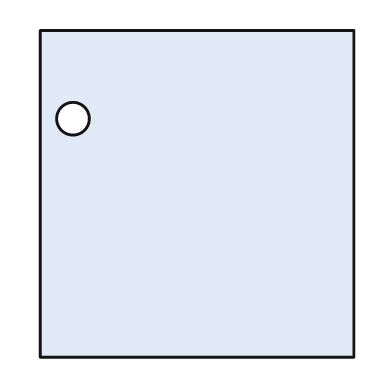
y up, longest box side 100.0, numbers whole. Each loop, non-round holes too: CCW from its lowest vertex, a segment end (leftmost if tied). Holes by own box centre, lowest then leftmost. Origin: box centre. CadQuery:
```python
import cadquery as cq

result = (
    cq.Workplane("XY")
    .moveTo(-48.0, -50.0)
    .lineTo(48.0, -50.0)
    .lineTo(48.0, 50.0)
    .lineTo(-48.0, 50.0)
    .close()
    .moveTo(-38.0, 23.0)
    .circle(5.0)
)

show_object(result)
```